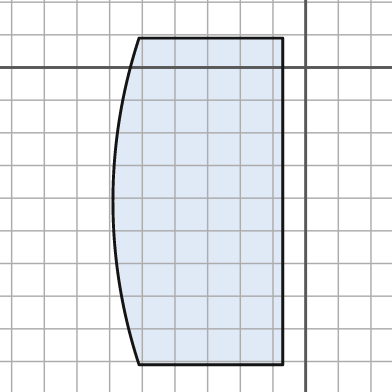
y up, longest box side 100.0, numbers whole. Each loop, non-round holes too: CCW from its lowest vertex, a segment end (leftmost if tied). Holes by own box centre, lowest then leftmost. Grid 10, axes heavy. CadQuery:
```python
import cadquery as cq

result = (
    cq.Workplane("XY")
    .moveTo(-51.0, -91.0)
    .lineTo(-7.0, -91.0)
    .lineTo(-7.0, 9.0)
    .lineTo(-51.0, 9.0)
    .threePointArc((-59.0, -41.0), (-51.0, -91.0))
    .close()
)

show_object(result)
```